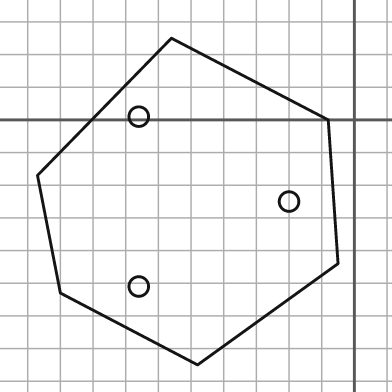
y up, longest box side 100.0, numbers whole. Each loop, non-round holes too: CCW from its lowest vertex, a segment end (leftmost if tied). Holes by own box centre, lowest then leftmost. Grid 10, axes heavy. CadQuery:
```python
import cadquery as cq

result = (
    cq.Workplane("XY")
    .moveTo(-48.0, -75.0)
    .lineTo(-5.0, -44.0)
    .lineTo(-8.0, 0.0)
    .lineTo(-56.0, 25.0)
    .lineTo(-97.0, -17.0)
    .lineTo(-90.0, -53.0)
    .close()
    .moveTo(-66.0, -51.0)
    .circle(3.0)
    .moveTo(-20.0, -25.0)
    .circle(3.0)
    .moveTo(-66.0, 1.0)
    .circle(3.0)
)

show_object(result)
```